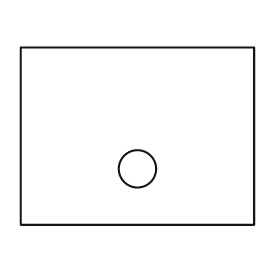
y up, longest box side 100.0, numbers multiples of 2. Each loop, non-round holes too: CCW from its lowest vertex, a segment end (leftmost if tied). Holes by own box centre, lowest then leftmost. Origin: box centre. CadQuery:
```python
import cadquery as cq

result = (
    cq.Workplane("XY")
    .moveTo(-50.0, -38.0)
    .lineTo(50.0, -38.0)
    .lineTo(50.0, 38.0)
    .lineTo(-50.0, 38.0)
    .close()
    .moveTo(0.0, -14.0)
    .circle(8.0)
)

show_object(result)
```